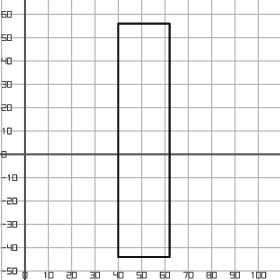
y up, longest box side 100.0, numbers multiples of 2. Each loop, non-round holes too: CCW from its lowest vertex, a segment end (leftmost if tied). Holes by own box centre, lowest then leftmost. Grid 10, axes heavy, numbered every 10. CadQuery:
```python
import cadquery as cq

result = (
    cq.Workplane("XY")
    .moveTo(40.0, -44.0)
    .lineTo(62.0, -44.0)
    .lineTo(62.0, 56.0)
    .lineTo(40.0, 56.0)
    .close()
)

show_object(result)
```